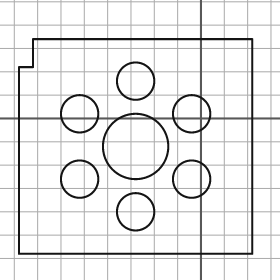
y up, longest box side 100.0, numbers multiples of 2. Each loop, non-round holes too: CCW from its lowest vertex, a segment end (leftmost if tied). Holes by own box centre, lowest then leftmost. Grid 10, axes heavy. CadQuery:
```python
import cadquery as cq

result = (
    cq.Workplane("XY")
    .moveTo(-78.0, -58.0)
    .lineTo(22.0, -58.0)
    .lineTo(22.0, 34.0)
    .lineTo(-72.0, 34.0)
    .lineTo(-72.0, 22.0)
    .lineTo(-78.0, 22.0)
    .close()
    .moveTo(-28.0, -40.0)
    .circle(8.0)
    .moveTo(-52.0, -26.0)
    .circle(8.0)
    .moveTo(-4.0, -26.0)
    .circle(8.0)
    .moveTo(-28.0, -12.0)
    .circle(14.0)
    .moveTo(-52.0, 2.0)
    .circle(8.0)
    .moveTo(-4.0, 2.0)
    .circle(8.0)
    .moveTo(-28.0, 16.0)
    .circle(8.0)
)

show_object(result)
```